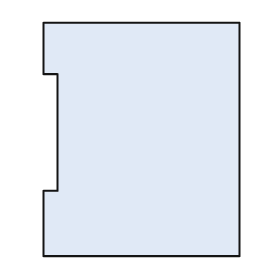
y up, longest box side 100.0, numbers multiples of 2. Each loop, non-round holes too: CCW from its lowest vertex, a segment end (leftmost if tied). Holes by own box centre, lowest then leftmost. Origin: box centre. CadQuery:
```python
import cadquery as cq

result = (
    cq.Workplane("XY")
    .moveTo(-42.0, -50.0)
    .lineTo(42.0, -50.0)
    .lineTo(42.0, 50.0)
    .lineTo(-42.0, 50.0)
    .lineTo(-42.0, 28.0)
    .lineTo(-36.0, 28.0)
    .lineTo(-36.0, -22.0)
    .lineTo(-42.0, -22.0)
    .close()
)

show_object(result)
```